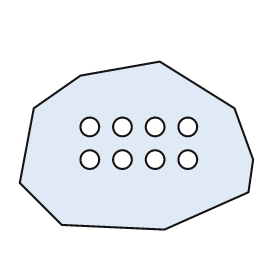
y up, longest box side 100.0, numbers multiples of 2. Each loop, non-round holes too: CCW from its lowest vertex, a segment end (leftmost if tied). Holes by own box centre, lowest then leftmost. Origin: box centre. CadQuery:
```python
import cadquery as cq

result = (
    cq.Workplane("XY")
    .moveTo(12.0, -36.0)
    .lineTo(48.0, -20.0)
    .lineTo(50.0, -6.0)
    .lineTo(42.0, 16.0)
    .lineTo(10.0, 36.0)
    .lineTo(-24.0, 30.0)
    .lineTo(-44.0, 16.0)
    .lineTo(-50.0, -16.0)
    .lineTo(-32.0, -34.0)
    .close()
    .moveTo(-20.0, -6.0)
    .circle(4.0)
    .moveTo(-6.0, -6.0)
    .circle(4.0)
    .moveTo(8.0, -6.0)
    .circle(4.0)
    .moveTo(22.0, -6.0)
    .circle(4.0)
    .moveTo(-20.0, 8.0)
    .circle(4.0)
    .moveTo(-6.0, 8.0)
    .circle(4.0)
    .moveTo(8.0, 8.0)
    .circle(4.0)
    .moveTo(22.0, 8.0)
    .circle(4.0)
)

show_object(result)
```